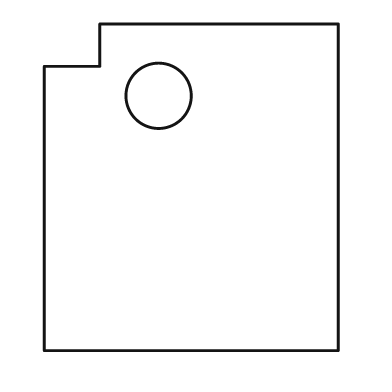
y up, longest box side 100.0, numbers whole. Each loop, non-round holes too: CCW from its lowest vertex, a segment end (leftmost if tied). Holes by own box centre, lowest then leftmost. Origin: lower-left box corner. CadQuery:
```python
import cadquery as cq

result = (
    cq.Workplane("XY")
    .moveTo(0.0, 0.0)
    .lineTo(90.0, 0.0)
    .lineTo(90.0, 100.0)
    .lineTo(17.0, 100.0)
    .lineTo(17.0, 87.0)
    .lineTo(0.0, 87.0)
    .close()
    .moveTo(35.0, 78.0)
    .circle(10.0)
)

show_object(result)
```